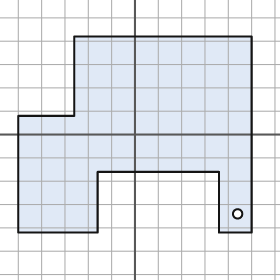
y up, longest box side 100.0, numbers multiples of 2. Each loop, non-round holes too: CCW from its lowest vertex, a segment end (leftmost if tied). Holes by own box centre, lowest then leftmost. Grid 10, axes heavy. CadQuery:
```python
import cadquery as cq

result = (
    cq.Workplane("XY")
    .moveTo(-50.0, -42.0)
    .lineTo(-16.0, -42.0)
    .lineTo(-16.0, -16.0)
    .lineTo(36.0, -16.0)
    .lineTo(36.0, -42.0)
    .lineTo(50.0, -42.0)
    .lineTo(50.0, 42.0)
    .lineTo(-26.0, 42.0)
    .lineTo(-26.0, 8.0)
    .lineTo(-50.0, 8.0)
    .close()
    .moveTo(44.0, -34.0)
    .circle(2.0)
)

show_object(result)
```